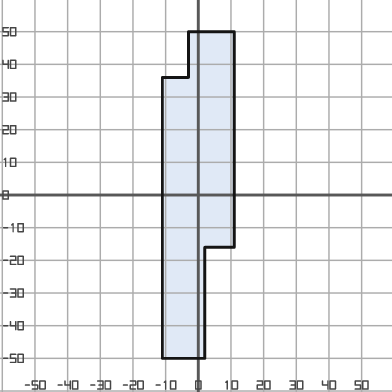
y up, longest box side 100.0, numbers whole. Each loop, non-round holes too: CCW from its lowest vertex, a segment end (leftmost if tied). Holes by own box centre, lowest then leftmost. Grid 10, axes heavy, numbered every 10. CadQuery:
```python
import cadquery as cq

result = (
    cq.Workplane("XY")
    .moveTo(-11.0, -50.0)
    .lineTo(2.0, -50.0)
    .lineTo(2.0, -16.0)
    .lineTo(11.0, -16.0)
    .lineTo(11.0, 50.0)
    .lineTo(-3.0, 50.0)
    .lineTo(-3.0, 36.0)
    .lineTo(-11.0, 36.0)
    .close()
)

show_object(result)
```